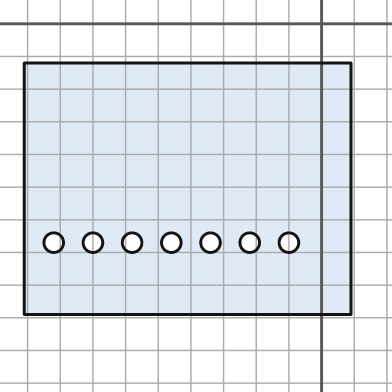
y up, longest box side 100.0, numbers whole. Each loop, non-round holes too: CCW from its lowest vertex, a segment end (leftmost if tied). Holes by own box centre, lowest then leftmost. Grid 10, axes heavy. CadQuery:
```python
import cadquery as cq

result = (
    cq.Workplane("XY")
    .moveTo(-91.0, -89.0)
    .lineTo(9.0, -89.0)
    .lineTo(9.0, -12.0)
    .lineTo(-91.0, -12.0)
    .close()
    .moveTo(-82.0, -67.0)
    .circle(3.0)
    .moveTo(-70.0, -67.0)
    .circle(3.0)
    .moveTo(-58.0, -67.0)
    .circle(3.0)
    .moveTo(-46.0, -67.0)
    .circle(3.0)
    .moveTo(-34.0, -67.0)
    .circle(3.0)
    .moveTo(-22.0, -67.0)
    .circle(3.0)
    .moveTo(-10.0, -67.0)
    .circle(3.0)
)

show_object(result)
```